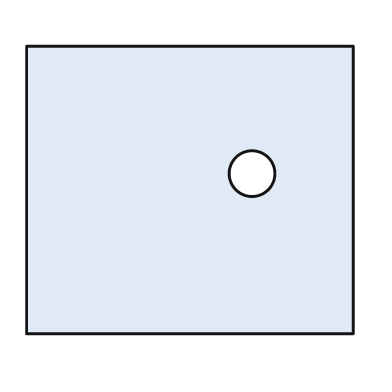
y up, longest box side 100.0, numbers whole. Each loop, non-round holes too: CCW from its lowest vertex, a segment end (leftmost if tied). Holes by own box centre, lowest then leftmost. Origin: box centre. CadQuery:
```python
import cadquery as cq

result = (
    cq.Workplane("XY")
    .moveTo(-50.0, -44.0)
    .lineTo(50.0, -44.0)
    .lineTo(50.0, 44.0)
    .lineTo(-50.0, 44.0)
    .close()
    .moveTo(19.0, 5.0)
    .circle(7.0)
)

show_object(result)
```